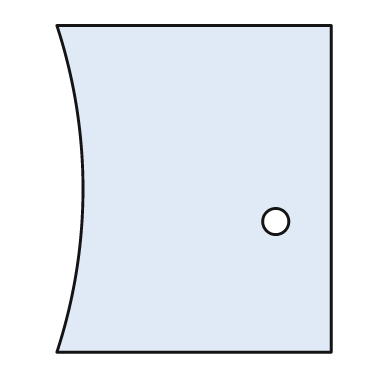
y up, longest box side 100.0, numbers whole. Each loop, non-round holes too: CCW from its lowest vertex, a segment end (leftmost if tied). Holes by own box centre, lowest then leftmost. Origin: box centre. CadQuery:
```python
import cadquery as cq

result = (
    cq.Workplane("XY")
    .moveTo(-42.0, -50.0)
    .lineTo(42.0, -50.0)
    .lineTo(42.0, 50.0)
    .lineTo(-42.0, 50.0)
    .threePointArc((-34.0, 0.0), (-42.0, -50.0))
    .close()
    .moveTo(25.0, -10.0)
    .circle(4.0)
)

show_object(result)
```